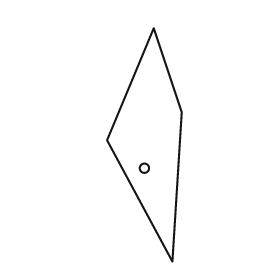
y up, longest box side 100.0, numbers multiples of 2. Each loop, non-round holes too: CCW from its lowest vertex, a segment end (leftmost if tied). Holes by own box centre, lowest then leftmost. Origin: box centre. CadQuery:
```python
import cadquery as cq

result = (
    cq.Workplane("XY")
    .moveTo(12.0, -50.0)
    .lineTo(16.0, 14.0)
    .lineTo(4.0, 50.0)
    .lineTo(-16.0, 2.0)
    .close()
    .moveTo(0.0, -10.0)
    .circle(2.0)
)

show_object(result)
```